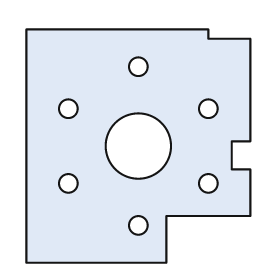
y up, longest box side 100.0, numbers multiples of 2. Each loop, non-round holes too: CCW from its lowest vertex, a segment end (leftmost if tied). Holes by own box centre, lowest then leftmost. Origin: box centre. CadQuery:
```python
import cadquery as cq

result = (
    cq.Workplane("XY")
    .moveTo(-48.0, -50.0)
    .lineTo(12.0, -50.0)
    .lineTo(12.0, -30.0)
    .lineTo(48.0, -30.0)
    .lineTo(48.0, -10.0)
    .lineTo(40.0, -10.0)
    .lineTo(40.0, 2.0)
    .lineTo(48.0, 2.0)
    .lineTo(48.0, 46.0)
    .lineTo(30.0, 46.0)
    .lineTo(30.0, 50.0)
    .lineTo(-48.0, 50.0)
    .close()
    .moveTo(0.0, -34.0)
    .circle(4.0)
    .moveTo(-30.0, -16.0)
    .circle(4.0)
    .moveTo(30.0, -16.0)
    .circle(4.0)
    .moveTo(0.0, 0.0)
    .circle(14.0)
    .moveTo(-30.0, 16.0)
    .circle(4.0)
    .moveTo(30.0, 16.0)
    .circle(4.0)
    .moveTo(0.0, 34.0)
    .circle(4.0)
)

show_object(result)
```